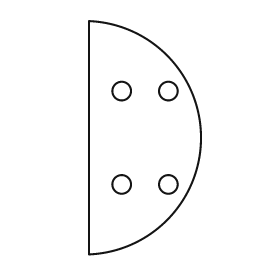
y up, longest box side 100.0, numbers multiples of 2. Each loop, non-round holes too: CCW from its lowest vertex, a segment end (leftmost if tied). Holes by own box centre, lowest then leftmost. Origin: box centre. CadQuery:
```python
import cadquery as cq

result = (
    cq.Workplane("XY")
    .moveTo(-24.0, -50.0)
    .threePointArc((24.0, 0.0), (-24.0, 50.0))
    .close()
    .moveTo(-10.0, -20.0)
    .circle(4.0)
    .moveTo(10.0, -20.0)
    .circle(4.0)
    .moveTo(-10.0, 20.0)
    .circle(4.0)
    .moveTo(10.0, 20.0)
    .circle(4.0)
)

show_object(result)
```